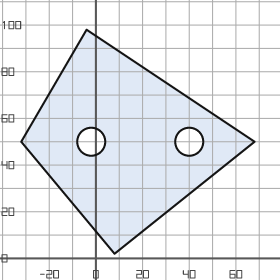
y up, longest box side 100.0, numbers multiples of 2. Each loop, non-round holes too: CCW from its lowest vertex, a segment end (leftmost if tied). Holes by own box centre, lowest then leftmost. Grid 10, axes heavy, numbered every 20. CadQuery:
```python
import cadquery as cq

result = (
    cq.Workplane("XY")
    .moveTo(8.0, 2.0)
    .lineTo(68.0, 50.0)
    .lineTo(-4.0, 98.0)
    .lineTo(-32.0, 50.0)
    .close()
    .moveTo(-2.0, 50.0)
    .circle(6.0)
    .moveTo(40.0, 50.0)
    .circle(6.0)
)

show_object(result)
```